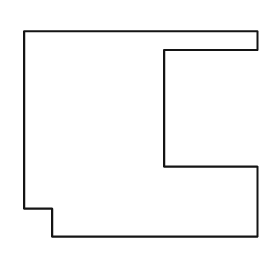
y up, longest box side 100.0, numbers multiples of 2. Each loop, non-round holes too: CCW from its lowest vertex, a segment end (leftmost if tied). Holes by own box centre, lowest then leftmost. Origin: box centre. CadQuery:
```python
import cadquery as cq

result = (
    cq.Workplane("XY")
    .moveTo(-38.0, -44.0)
    .lineTo(50.0, -44.0)
    .lineTo(50.0, -14.0)
    .lineTo(10.0, -14.0)
    .lineTo(10.0, 36.0)
    .lineTo(50.0, 36.0)
    .lineTo(50.0, 44.0)
    .lineTo(-50.0, 44.0)
    .lineTo(-50.0, -32.0)
    .lineTo(-38.0, -32.0)
    .close()
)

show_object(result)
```